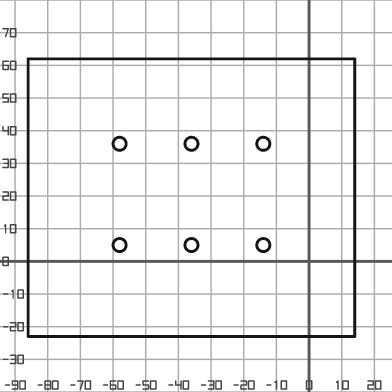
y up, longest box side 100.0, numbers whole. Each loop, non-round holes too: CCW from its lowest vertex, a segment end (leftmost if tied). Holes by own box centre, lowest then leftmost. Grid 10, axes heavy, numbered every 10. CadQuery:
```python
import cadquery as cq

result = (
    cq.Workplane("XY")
    .moveTo(-86.0, -23.0)
    .lineTo(14.0, -23.0)
    .lineTo(14.0, 62.0)
    .lineTo(-86.0, 62.0)
    .close()
    .moveTo(-58.0, 5.0)
    .circle(2.0)
    .moveTo(-36.0, 5.0)
    .circle(2.0)
    .moveTo(-14.0, 5.0)
    .circle(2.0)
    .moveTo(-58.0, 36.0)
    .circle(2.0)
    .moveTo(-36.0, 36.0)
    .circle(2.0)
    .moveTo(-14.0, 36.0)
    .circle(2.0)
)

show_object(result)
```